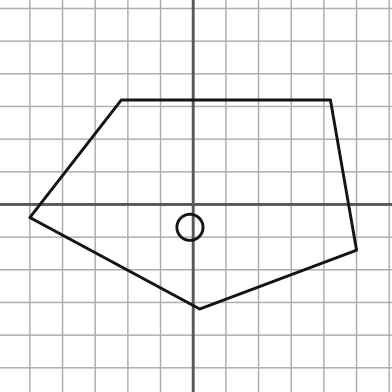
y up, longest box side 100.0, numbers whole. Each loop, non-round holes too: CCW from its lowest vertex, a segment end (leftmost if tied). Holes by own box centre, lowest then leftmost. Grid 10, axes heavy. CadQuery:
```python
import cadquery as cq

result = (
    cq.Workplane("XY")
    .moveTo(2.0, -32.0)
    .lineTo(50.0, -14.0)
    .lineTo(42.0, 32.0)
    .lineTo(-22.0, 32.0)
    .lineTo(-50.0, -4.0)
    .close()
    .moveTo(-1.0, -7.0)
    .circle(4.0)
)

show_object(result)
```